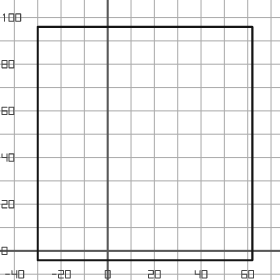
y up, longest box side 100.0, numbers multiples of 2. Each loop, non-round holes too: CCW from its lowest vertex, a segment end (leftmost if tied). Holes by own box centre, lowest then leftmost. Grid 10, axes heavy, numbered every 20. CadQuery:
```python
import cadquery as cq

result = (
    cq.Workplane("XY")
    .moveTo(-30.0, -4.0)
    .lineTo(62.0, -4.0)
    .lineTo(62.0, 96.0)
    .lineTo(-30.0, 96.0)
    .close()
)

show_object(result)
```